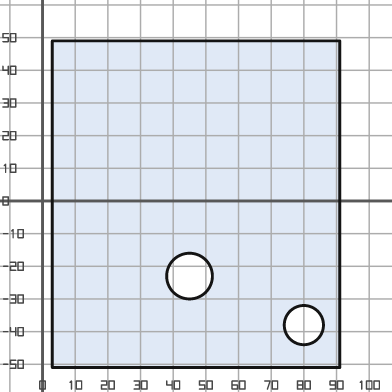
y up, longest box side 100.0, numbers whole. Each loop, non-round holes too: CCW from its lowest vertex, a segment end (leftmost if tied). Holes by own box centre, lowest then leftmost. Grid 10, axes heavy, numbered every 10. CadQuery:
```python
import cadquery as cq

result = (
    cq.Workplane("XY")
    .moveTo(3.0, -51.0)
    .lineTo(91.0, -51.0)
    .lineTo(91.0, 49.0)
    .lineTo(3.0, 49.0)
    .close()
    .moveTo(80.0, -38.0)
    .circle(6.0)
    .moveTo(45.0, -23.0)
    .circle(7.0)
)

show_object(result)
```